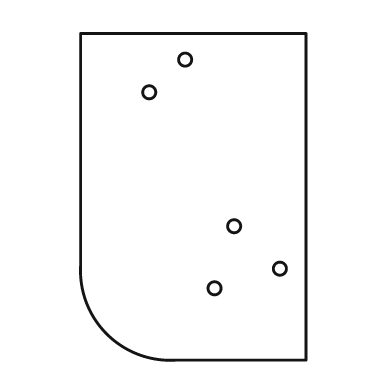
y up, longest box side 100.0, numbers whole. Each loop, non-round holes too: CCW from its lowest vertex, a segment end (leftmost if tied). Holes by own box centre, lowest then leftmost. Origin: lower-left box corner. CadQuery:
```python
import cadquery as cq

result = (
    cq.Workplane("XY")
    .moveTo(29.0, 0.0)
    .lineTo(69.0, 0.0)
    .lineTo(69.0, 100.0)
    .lineTo(0.0, 100.0)
    .lineTo(0.0, 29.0)
    .threePointArc((8.0, 8.0), (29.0, 0.0))
    .close()
    .moveTo(41.0, 22.0)
    .circle(2.0)
    .moveTo(61.0, 28.0)
    .circle(2.0)
    .moveTo(47.0, 41.0)
    .circle(2.0)
    .moveTo(21.0, 82.0)
    .circle(2.0)
    .moveTo(32.0, 92.0)
    .circle(2.0)
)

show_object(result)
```